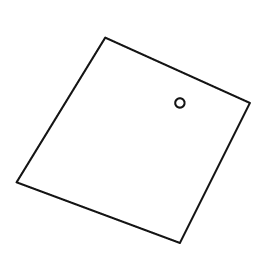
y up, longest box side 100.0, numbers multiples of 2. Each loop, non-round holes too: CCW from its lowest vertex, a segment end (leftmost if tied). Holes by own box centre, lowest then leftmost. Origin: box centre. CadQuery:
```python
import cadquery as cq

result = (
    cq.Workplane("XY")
    .moveTo(20.0, -44.0)
    .lineTo(50.0, 16.0)
    .lineTo(-12.0, 44.0)
    .lineTo(-50.0, -18.0)
    .close()
    .moveTo(20.0, 16.0)
    .circle(2.0)
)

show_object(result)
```